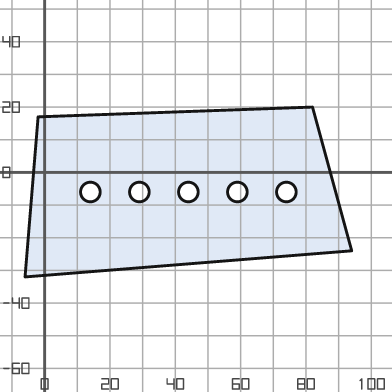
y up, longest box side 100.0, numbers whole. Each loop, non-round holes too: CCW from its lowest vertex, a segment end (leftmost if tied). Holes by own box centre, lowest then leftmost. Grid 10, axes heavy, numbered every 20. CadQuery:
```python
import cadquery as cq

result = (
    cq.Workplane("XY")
    .moveTo(-6.0, -32.0)
    .lineTo(94.0, -24.0)
    .lineTo(82.0, 20.0)
    .lineTo(-2.0, 17.0)
    .close()
    .moveTo(14.0, -6.0)
    .circle(3.0)
    .moveTo(29.0, -6.0)
    .circle(3.0)
    .moveTo(44.0, -6.0)
    .circle(3.0)
    .moveTo(59.0, -6.0)
    .circle(3.0)
    .moveTo(74.0, -6.0)
    .circle(3.0)
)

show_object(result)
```